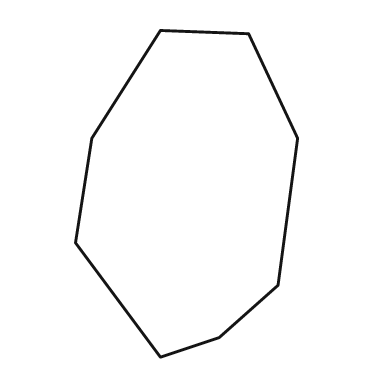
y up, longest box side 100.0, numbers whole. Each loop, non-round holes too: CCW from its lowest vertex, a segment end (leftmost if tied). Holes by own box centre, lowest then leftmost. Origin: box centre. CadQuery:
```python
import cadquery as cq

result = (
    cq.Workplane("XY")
    .moveTo(-8.0, -50.0)
    .lineTo(10.0, -44.0)
    .lineTo(28.0, -28.0)
    .lineTo(34.0, 17.0)
    .lineTo(19.0, 49.0)
    .lineTo(-8.0, 50.0)
    .lineTo(-29.0, 17.0)
    .lineTo(-34.0, -15.0)
    .close()
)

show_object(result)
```